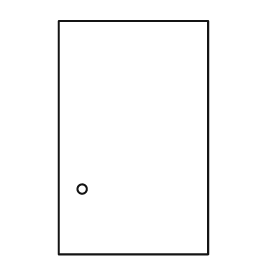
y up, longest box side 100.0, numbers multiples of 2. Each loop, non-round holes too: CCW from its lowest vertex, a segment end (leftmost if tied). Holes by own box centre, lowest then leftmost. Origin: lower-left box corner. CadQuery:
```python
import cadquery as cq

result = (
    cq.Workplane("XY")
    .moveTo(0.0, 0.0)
    .lineTo(64.0, 0.0)
    .lineTo(64.0, 100.0)
    .lineTo(0.0, 100.0)
    .close()
    .moveTo(10.0, 28.0)
    .circle(2.0)
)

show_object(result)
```